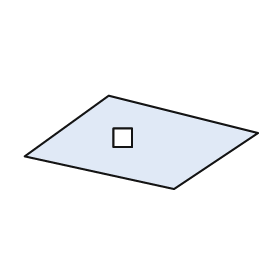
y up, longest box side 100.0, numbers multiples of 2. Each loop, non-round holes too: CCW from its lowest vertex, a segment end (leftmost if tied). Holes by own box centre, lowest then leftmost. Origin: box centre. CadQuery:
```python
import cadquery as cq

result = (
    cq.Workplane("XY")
    .moveTo(14.0, -20.0)
    .lineTo(50.0, 4.0)
    .lineTo(-14.0, 20.0)
    .lineTo(-50.0, -6.0)
    .close()
    .moveTo(-12.0, -2.0)
    .lineTo(-4.0, -2.0)
    .lineTo(-4.0, 6.0)
    .lineTo(-12.0, 6.0)
    .close()
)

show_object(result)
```